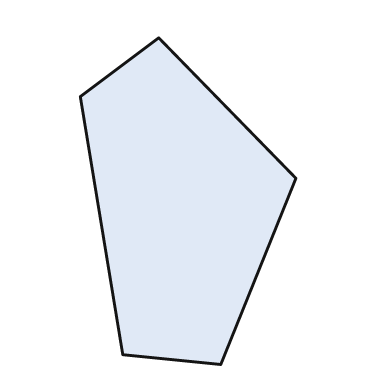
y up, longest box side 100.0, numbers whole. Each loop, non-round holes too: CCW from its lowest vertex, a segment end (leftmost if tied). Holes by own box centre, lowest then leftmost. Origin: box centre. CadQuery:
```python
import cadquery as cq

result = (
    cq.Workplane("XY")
    .moveTo(10.0, -50.0)
    .lineTo(33.0, 7.0)
    .lineTo(-9.0, 50.0)
    .lineTo(-33.0, 32.0)
    .lineTo(-20.0, -47.0)
    .close()
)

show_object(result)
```